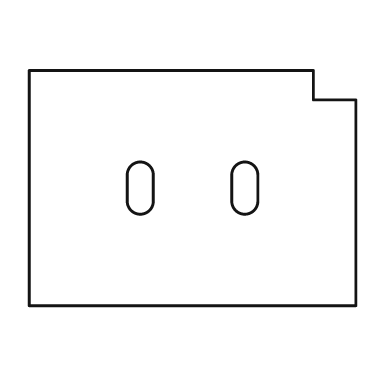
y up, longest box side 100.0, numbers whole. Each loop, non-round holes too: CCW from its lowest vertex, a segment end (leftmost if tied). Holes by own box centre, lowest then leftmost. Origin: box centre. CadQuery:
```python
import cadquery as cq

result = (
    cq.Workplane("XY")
    .moveTo(-50.0, -36.0)
    .lineTo(50.0, -36.0)
    .lineTo(50.0, 27.0)
    .lineTo(37.0, 27.0)
    .lineTo(37.0, 36.0)
    .lineTo(-50.0, 36.0)
    .close()
    .moveTo(-20.0, -4.0)
    .threePointArc((-16.0, -8.0), (-12.0, -4.0))
    .lineTo(-12.0, 4.0)
    .threePointArc((-16.0, 8.0), (-20.0, 4.0))
    .close()
    .moveTo(12.0, -4.0)
    .threePointArc((16.0, -8.0), (20.0, -4.0))
    .lineTo(20.0, 4.0)
    .threePointArc((16.0, 8.0), (12.0, 4.0))
    .close()
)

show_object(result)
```